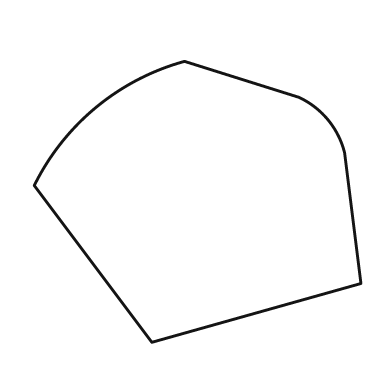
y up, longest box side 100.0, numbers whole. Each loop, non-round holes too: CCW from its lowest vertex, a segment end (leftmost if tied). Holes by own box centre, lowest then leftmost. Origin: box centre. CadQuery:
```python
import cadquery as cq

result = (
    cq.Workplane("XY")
    .moveTo(-14.0, -43.0)
    .lineTo(50.0, -25.0)
    .lineTo(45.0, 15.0)
    .threePointArc((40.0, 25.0), (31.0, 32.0))
    .lineTo(-4.0, 43.0)
    .threePointArc((-31.0, 29.0), (-50.0, 5.0))
    .close()
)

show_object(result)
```